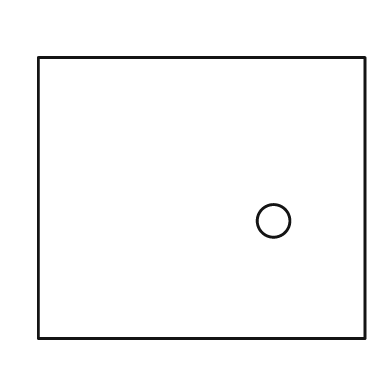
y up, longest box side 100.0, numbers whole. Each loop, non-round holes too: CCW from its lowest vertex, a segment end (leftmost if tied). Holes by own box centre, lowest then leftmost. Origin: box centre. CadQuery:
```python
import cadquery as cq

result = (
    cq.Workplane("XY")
    .moveTo(-50.0, -43.0)
    .lineTo(50.0, -43.0)
    .lineTo(50.0, 43.0)
    .lineTo(-50.0, 43.0)
    .close()
    .moveTo(22.0, -7.0)
    .circle(5.0)
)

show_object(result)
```